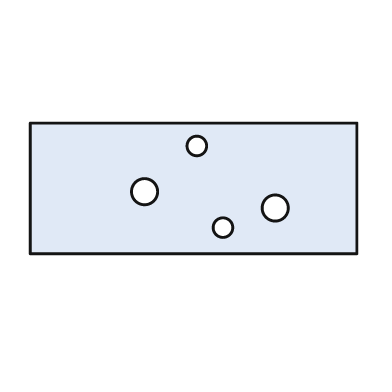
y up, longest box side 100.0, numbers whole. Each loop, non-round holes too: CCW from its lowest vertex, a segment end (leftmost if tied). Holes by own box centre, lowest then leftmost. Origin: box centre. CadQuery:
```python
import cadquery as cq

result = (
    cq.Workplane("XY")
    .moveTo(-50.0, -20.0)
    .lineTo(50.0, -20.0)
    .lineTo(50.0, 20.0)
    .lineTo(-50.0, 20.0)
    .close()
    .moveTo(9.0, -12.0)
    .circle(3.0)
    .moveTo(25.0, -6.0)
    .circle(4.0)
    .moveTo(-15.0, -1.0)
    .circle(4.0)
    .moveTo(1.0, 13.0)
    .circle(3.0)
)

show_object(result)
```